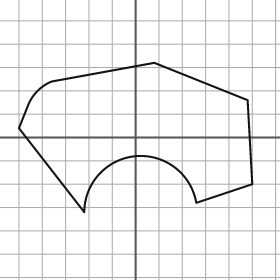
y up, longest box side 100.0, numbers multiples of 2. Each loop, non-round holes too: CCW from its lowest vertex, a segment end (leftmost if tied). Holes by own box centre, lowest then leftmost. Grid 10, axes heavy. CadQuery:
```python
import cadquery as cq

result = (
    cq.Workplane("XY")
    .moveTo(-22.0, -32.0)
    .threePointArc((0.0, -8.0), (26.0, -28.0))
    .lineTo(50.0, -20.0)
    .lineTo(48.0, 16.0)
    .lineTo(8.0, 32.0)
    .lineTo(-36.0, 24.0)
    .threePointArc((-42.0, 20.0), (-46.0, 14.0))
    .lineTo(-50.0, 4.0)
    .close()
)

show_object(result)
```